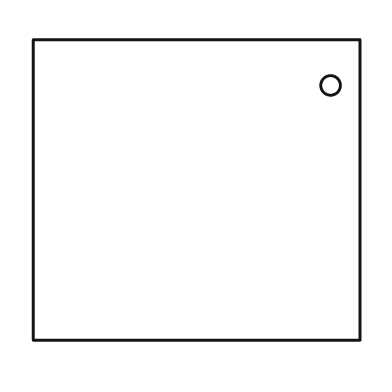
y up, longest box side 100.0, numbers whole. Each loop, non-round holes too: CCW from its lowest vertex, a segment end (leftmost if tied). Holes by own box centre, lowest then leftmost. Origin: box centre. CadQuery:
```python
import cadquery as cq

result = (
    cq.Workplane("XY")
    .moveTo(-50.0, -46.0)
    .lineTo(50.0, -46.0)
    .lineTo(50.0, 46.0)
    .lineTo(-50.0, 46.0)
    .close()
    .moveTo(41.0, 32.0)
    .circle(3.0)
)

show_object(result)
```